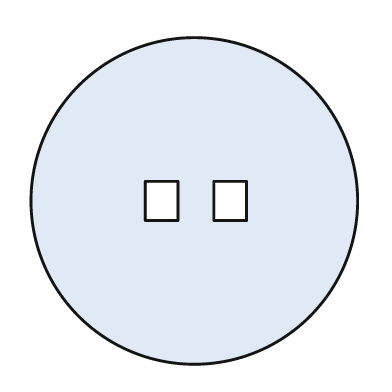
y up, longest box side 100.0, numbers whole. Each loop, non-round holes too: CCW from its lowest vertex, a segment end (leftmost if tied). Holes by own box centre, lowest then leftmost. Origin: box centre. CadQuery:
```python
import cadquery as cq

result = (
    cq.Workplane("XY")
    .moveTo(0.0, 0.0)
    .circle(50.0)
    .moveTo(-15.0, -6.0)
    .lineTo(-5.0, -6.0)
    .lineTo(-5.0, 6.0)
    .lineTo(-15.0, 6.0)
    .close()
    .moveTo(6.0, -6.0)
    .lineTo(16.0, -6.0)
    .lineTo(16.0, 6.0)
    .lineTo(6.0, 6.0)
    .close()
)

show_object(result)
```